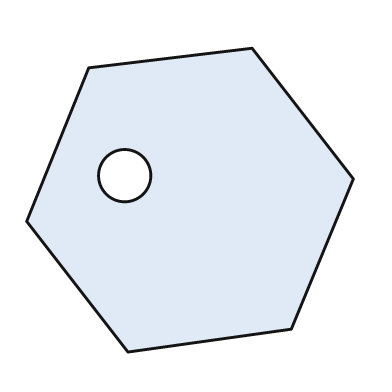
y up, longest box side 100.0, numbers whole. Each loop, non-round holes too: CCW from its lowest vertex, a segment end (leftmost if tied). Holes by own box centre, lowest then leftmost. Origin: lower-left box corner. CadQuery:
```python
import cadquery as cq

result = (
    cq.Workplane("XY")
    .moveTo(31.0, 0.0)
    .lineTo(81.0, 7.0)
    .lineTo(100.0, 53.0)
    .lineTo(69.0, 93.0)
    .lineTo(19.0, 87.0)
    .lineTo(0.0, 40.0)
    .close()
    .moveTo(30.0, 54.0)
    .circle(8.0)
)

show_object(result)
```